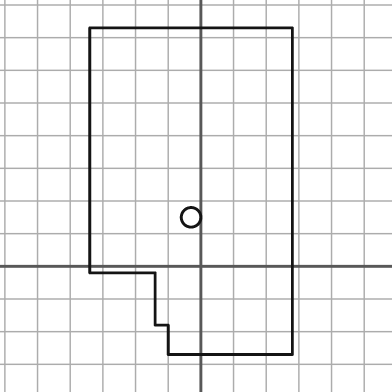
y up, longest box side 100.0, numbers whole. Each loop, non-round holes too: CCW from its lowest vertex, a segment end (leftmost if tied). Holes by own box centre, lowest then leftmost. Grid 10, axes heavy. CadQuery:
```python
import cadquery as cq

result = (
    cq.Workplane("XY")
    .moveTo(-10.0, -27.0)
    .lineTo(28.0, -27.0)
    .lineTo(28.0, 73.0)
    .lineTo(-34.0, 73.0)
    .lineTo(-34.0, -2.0)
    .lineTo(-14.0, -2.0)
    .lineTo(-14.0, -18.0)
    .lineTo(-10.0, -18.0)
    .close()
    .moveTo(-3.0, 15.0)
    .circle(3.0)
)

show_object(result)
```